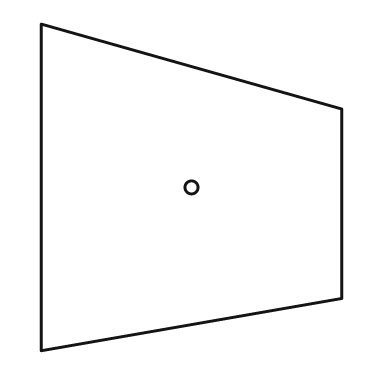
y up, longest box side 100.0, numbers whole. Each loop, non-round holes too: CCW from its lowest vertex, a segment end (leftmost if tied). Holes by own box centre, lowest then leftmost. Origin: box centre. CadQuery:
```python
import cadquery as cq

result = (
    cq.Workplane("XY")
    .moveTo(-46.0, -50.0)
    .lineTo(46.0, -34.0)
    .lineTo(46.0, 24.0)
    .lineTo(-46.0, 50.0)
    .close()
    .moveTo(0.0, 0.0)
    .circle(2.0)
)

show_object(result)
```